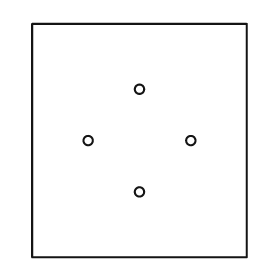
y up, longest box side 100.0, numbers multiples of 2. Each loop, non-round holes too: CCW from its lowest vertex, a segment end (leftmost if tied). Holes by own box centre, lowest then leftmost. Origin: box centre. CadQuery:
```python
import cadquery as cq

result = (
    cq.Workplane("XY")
    .moveTo(-46.0, -50.0)
    .lineTo(46.0, -50.0)
    .lineTo(46.0, 50.0)
    .lineTo(-46.0, 50.0)
    .close()
    .moveTo(0.0, -22.0)
    .circle(2.0)
    .moveTo(-22.0, 0.0)
    .circle(2.0)
    .moveTo(22.0, 0.0)
    .circle(2.0)
    .moveTo(0.0, 22.0)
    .circle(2.0)
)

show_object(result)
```